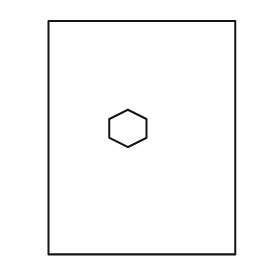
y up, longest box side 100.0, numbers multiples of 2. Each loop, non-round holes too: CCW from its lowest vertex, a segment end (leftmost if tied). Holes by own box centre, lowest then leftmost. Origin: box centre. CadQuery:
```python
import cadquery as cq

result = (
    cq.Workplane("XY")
    .moveTo(-40.0, -50.0)
    .lineTo(40.0, -50.0)
    .lineTo(40.0, 50.0)
    .lineTo(-40.0, 50.0)
    .close()
    .moveTo(-6.0, -4.0)
    .lineTo(2.0, 0.0)
    .lineTo(2.0, 8.0)
    .lineTo(-6.0, 12.0)
    .lineTo(-14.0, 8.0)
    .lineTo(-14.0, 0.0)
    .close()
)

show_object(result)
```